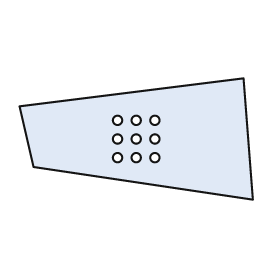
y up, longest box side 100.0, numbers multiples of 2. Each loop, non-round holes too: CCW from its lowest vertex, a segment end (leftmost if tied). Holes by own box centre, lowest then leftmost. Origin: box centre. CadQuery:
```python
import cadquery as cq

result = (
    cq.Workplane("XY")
    .moveTo(50.0, -26.0)
    .lineTo(46.0, 26.0)
    .lineTo(-50.0, 14.0)
    .lineTo(-44.0, -12.0)
    .close()
    .moveTo(-8.0, -8.0)
    .circle(2.0)
    .moveTo(0.0, -8.0)
    .circle(2.0)
    .moveTo(8.0, -8.0)
    .circle(2.0)
    .moveTo(-8.0, 0.0)
    .circle(2.0)
    .moveTo(0.0, 0.0)
    .circle(2.0)
    .moveTo(8.0, 0.0)
    .circle(2.0)
    .moveTo(-8.0, 8.0)
    .circle(2.0)
    .moveTo(0.0, 8.0)
    .circle(2.0)
    .moveTo(8.0, 8.0)
    .circle(2.0)
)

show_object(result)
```